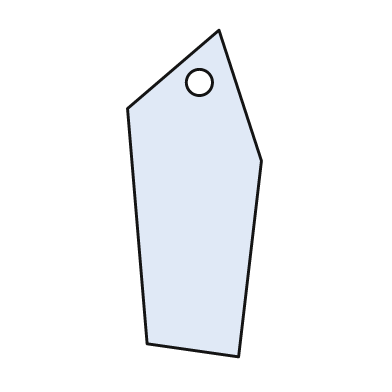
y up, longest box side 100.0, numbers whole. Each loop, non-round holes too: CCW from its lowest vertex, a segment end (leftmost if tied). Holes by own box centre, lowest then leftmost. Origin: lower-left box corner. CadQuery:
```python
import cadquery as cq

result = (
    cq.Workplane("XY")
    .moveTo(34.0, 0.0)
    .lineTo(41.0, 60.0)
    .lineTo(28.0, 100.0)
    .lineTo(0.0, 76.0)
    .lineTo(6.0, 4.0)
    .close()
    .moveTo(22.0, 84.0)
    .circle(4.0)
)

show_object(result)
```